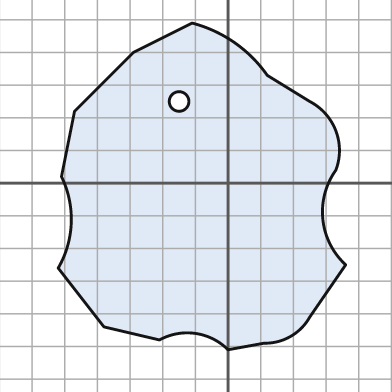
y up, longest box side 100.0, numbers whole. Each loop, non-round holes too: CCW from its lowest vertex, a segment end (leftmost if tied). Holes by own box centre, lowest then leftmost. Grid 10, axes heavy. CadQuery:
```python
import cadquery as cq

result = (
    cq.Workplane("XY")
    .moveTo(0.0, -51.0)
    .lineTo(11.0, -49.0)
    .threePointArc((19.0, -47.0), (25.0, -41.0))
    .lineTo(36.0, -25.0)
    .threePointArc((29.0, -11.0), (33.0, 4.0))
    .threePointArc((33.0, 16.0), (25.0, 25.0))
    .lineTo(12.0, 33.0)
    .threePointArc((2.0, 43.0), (-11.0, 49.0))
    .lineTo(-29.0, 40.0)
    .lineTo(-47.0, 22.0)
    .lineTo(-51.0, 2.0)
    .threePointArc((-48.0, -12.0), (-52.0, -26.0))
    .lineTo(-38.0, -44.0)
    .lineTo(-21.0, -48.0)
    .threePointArc((-10.0, -46.0), (0.0, -51.0))
    .close()
    .moveTo(-15.0, 25.0)
    .circle(3.0)
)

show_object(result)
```